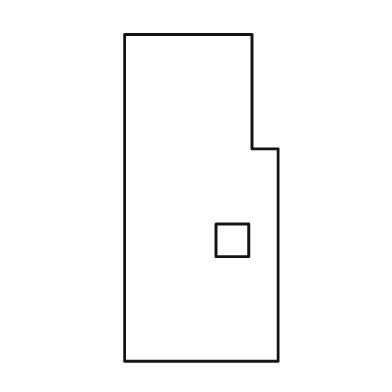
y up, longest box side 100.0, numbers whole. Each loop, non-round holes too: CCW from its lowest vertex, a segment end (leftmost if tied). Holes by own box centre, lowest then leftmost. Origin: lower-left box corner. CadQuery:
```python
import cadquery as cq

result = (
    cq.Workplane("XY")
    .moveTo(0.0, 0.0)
    .lineTo(47.0, 0.0)
    .lineTo(47.0, 65.0)
    .lineTo(39.0, 65.0)
    .lineTo(39.0, 100.0)
    .lineTo(0.0, 100.0)
    .close()
    .moveTo(28.0, 32.0)
    .lineTo(38.0, 32.0)
    .lineTo(38.0, 42.0)
    .lineTo(28.0, 42.0)
    .close()
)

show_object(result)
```